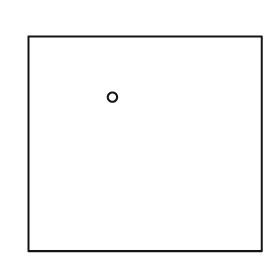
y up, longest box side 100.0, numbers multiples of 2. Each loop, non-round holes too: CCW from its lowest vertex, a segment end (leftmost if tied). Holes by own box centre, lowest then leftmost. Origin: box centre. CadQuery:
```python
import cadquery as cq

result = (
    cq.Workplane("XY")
    .moveTo(-50.0, -46.0)
    .lineTo(50.0, -46.0)
    .lineTo(50.0, 46.0)
    .lineTo(-50.0, 46.0)
    .close()
    .moveTo(-14.0, 20.0)
    .circle(2.0)
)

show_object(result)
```